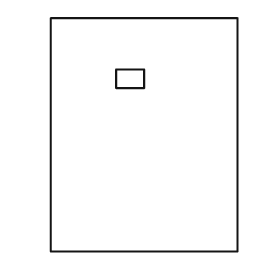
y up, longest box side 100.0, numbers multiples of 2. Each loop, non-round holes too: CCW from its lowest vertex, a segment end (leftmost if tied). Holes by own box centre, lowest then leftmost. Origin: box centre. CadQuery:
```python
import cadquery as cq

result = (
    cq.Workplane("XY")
    .moveTo(-40.0, -50.0)
    .lineTo(40.0, -50.0)
    .lineTo(40.0, 50.0)
    .lineTo(-40.0, 50.0)
    .close()
    .moveTo(-12.0, 20.0)
    .lineTo(0.0, 20.0)
    .lineTo(0.0, 28.0)
    .lineTo(-12.0, 28.0)
    .close()
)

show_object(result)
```